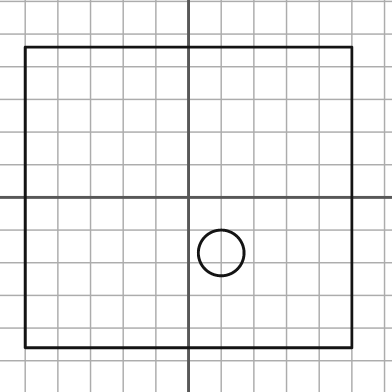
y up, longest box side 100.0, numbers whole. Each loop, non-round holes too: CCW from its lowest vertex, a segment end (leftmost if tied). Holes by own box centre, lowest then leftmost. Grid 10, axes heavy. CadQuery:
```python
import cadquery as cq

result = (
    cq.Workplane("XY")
    .moveTo(-50.0, -46.0)
    .lineTo(50.0, -46.0)
    .lineTo(50.0, 46.0)
    .lineTo(-50.0, 46.0)
    .close()
    .moveTo(10.0, -17.0)
    .circle(7.0)
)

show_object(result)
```